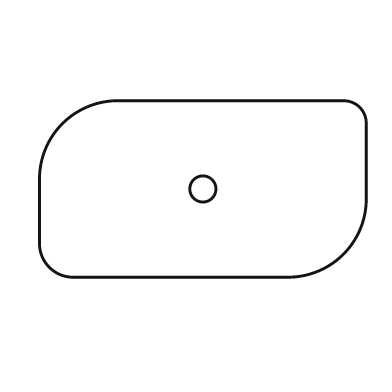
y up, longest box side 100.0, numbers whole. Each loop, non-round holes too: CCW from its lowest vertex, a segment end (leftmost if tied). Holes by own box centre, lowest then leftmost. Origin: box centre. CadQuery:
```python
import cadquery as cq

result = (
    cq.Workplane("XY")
    .moveTo(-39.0, -27.0)
    .lineTo(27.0, -27.0)
    .threePointArc((43.0, -20.0), (50.0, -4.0))
    .lineTo(50.0, 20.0)
    .threePointArc((48.0, 25.0), (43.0, 27.0))
    .lineTo(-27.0, 27.0)
    .threePointArc((-43.0, 20.0), (-50.0, 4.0))
    .lineTo(-50.0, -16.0)
    .threePointArc((-47.0, -24.0), (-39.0, -27.0))
    .close()
    .moveTo(0.0, 0.0)
    .circle(4.0)
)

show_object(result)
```